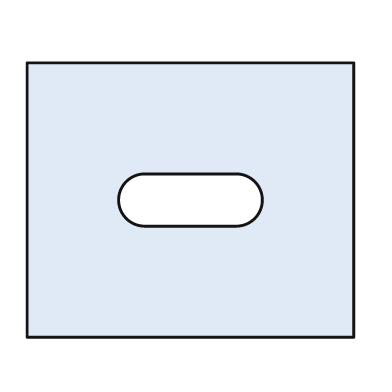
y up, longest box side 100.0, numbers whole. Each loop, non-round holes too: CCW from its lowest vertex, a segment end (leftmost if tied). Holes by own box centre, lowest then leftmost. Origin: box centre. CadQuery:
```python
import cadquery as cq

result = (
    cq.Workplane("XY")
    .moveTo(-50.0, -42.0)
    .lineTo(50.0, -42.0)
    .lineTo(50.0, 42.0)
    .lineTo(-50.0, 42.0)
    .close()
    .moveTo(-14.0, -8.0)
    .lineTo(14.0, -8.0)
    .threePointArc((22.0, 0.0), (14.0, 8.0))
    .lineTo(-14.0, 8.0)
    .threePointArc((-22.0, 0.0), (-14.0, -8.0))
    .close()
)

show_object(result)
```